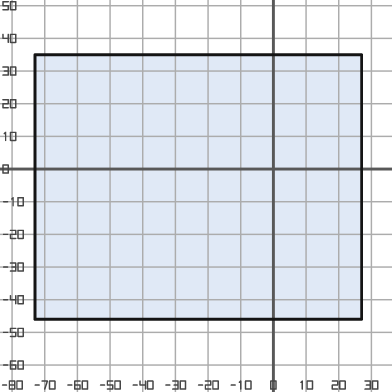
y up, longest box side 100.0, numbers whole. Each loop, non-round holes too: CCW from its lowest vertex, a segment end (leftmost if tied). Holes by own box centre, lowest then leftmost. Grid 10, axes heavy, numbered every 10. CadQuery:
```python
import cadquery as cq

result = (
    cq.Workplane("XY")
    .moveTo(-73.0, -46.0)
    .lineTo(27.0, -46.0)
    .lineTo(27.0, 35.0)
    .lineTo(-73.0, 35.0)
    .close()
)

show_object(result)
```